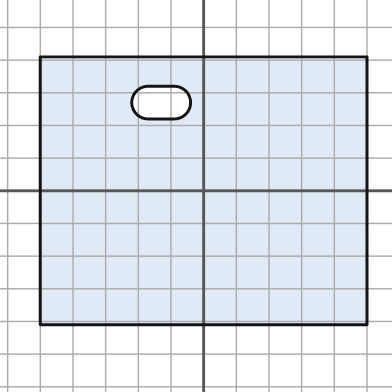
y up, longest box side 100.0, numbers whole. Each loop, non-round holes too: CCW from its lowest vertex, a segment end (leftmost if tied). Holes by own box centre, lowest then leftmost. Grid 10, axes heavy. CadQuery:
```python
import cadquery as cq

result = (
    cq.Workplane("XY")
    .moveTo(-50.0, -41.0)
    .lineTo(50.0, -41.0)
    .lineTo(50.0, 41.0)
    .lineTo(-50.0, 41.0)
    .close()
    .moveTo(-17.0, 22.0)
    .lineTo(-9.0, 22.0)
    .threePointArc((-4.0, 27.0), (-9.0, 32.0))
    .lineTo(-17.0, 32.0)
    .threePointArc((-22.0, 27.0), (-17.0, 22.0))
    .close()
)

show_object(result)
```